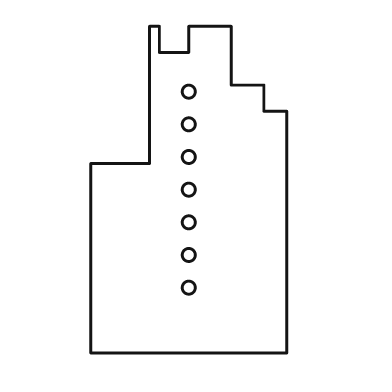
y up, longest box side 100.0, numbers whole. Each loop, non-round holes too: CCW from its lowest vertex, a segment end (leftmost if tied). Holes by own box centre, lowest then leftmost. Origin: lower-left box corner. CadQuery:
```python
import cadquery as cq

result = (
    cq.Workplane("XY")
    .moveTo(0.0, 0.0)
    .lineTo(60.0, 0.0)
    .lineTo(60.0, 74.0)
    .lineTo(53.0, 74.0)
    .lineTo(53.0, 82.0)
    .lineTo(43.0, 82.0)
    .lineTo(43.0, 100.0)
    .lineTo(30.0, 100.0)
    .lineTo(30.0, 92.0)
    .lineTo(21.0, 92.0)
    .lineTo(21.0, 100.0)
    .lineTo(18.0, 100.0)
    .lineTo(18.0, 58.0)
    .lineTo(0.0, 58.0)
    .close()
    .moveTo(30.0, 20.0)
    .circle(2.0)
    .moveTo(30.0, 30.0)
    .circle(2.0)
    .moveTo(30.0, 40.0)
    .circle(2.0)
    .moveTo(30.0, 50.0)
    .circle(2.0)
    .moveTo(30.0, 60.0)
    .circle(2.0)
    .moveTo(30.0, 70.0)
    .circle(2.0)
    .moveTo(30.0, 80.0)
    .circle(2.0)
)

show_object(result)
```